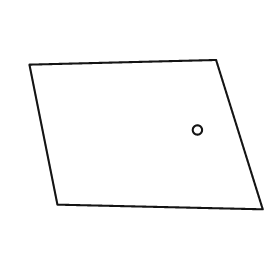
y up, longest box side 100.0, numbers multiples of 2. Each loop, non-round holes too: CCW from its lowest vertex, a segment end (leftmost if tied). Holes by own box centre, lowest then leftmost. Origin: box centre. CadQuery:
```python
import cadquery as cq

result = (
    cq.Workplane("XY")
    .moveTo(50.0, -32.0)
    .lineTo(30.0, 32.0)
    .lineTo(-50.0, 30.0)
    .lineTo(-38.0, -30.0)
    .close()
    .moveTo(22.0, 2.0)
    .circle(2.0)
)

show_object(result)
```